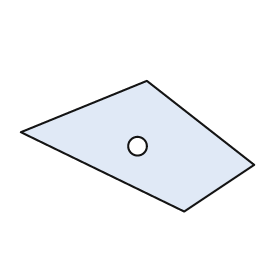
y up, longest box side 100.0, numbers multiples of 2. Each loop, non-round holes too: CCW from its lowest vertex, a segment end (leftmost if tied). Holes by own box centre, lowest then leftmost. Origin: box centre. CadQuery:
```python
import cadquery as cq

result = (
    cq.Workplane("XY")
    .moveTo(20.0, -28.0)
    .lineTo(50.0, -8.0)
    .lineTo(4.0, 28.0)
    .lineTo(-50.0, 6.0)
    .close()
    .moveTo(0.0, 0.0)
    .circle(4.0)
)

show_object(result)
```